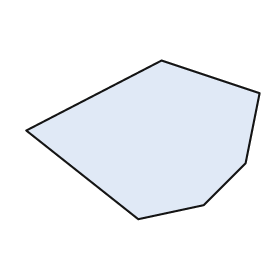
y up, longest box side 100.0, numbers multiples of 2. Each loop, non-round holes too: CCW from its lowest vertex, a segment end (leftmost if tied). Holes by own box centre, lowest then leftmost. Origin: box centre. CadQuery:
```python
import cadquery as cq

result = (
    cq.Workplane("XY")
    .moveTo(-2.0, -34.0)
    .lineTo(26.0, -28.0)
    .lineTo(44.0, -10.0)
    .lineTo(50.0, 20.0)
    .lineTo(8.0, 34.0)
    .lineTo(-50.0, 4.0)
    .close()
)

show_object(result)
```